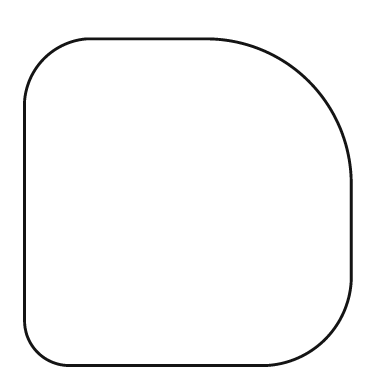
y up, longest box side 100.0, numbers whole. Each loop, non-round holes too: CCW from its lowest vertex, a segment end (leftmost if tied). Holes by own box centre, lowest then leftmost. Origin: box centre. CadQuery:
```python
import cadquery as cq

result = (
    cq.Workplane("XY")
    .moveTo(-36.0, -50.0)
    .lineTo(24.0, -50.0)
    .threePointArc((42.0, -42.0), (50.0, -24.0))
    .lineTo(50.0, 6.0)
    .threePointArc((37.0, 37.0), (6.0, 50.0))
    .lineTo(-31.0, 50.0)
    .threePointArc((-44.0, 44.0), (-50.0, 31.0))
    .lineTo(-50.0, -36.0)
    .threePointArc((-46.0, -46.0), (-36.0, -50.0))
    .close()
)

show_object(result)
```